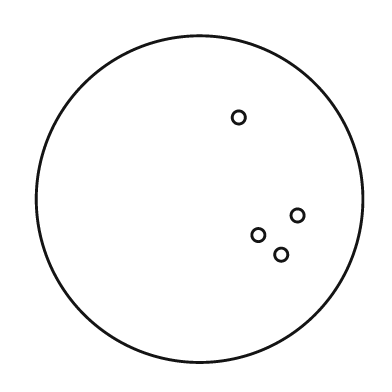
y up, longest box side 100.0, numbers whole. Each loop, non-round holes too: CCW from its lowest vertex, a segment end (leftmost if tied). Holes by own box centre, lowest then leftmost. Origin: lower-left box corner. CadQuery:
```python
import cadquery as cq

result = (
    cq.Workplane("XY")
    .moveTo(50.0, 50.0)
    .circle(50.0)
    .moveTo(75.0, 33.0)
    .circle(2.0)
    .moveTo(68.0, 39.0)
    .circle(2.0)
    .moveTo(80.0, 45.0)
    .circle(2.0)
    .moveTo(62.0, 75.0)
    .circle(2.0)
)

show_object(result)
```